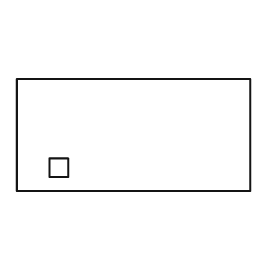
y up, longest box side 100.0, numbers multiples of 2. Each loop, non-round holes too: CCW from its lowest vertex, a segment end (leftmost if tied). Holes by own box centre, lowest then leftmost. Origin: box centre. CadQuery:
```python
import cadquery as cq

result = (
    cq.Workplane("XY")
    .moveTo(-50.0, -24.0)
    .lineTo(50.0, -24.0)
    .lineTo(50.0, 24.0)
    .lineTo(-50.0, 24.0)
    .close()
    .moveTo(-36.0, -18.0)
    .lineTo(-28.0, -18.0)
    .lineTo(-28.0, -10.0)
    .lineTo(-36.0, -10.0)
    .close()
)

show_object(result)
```